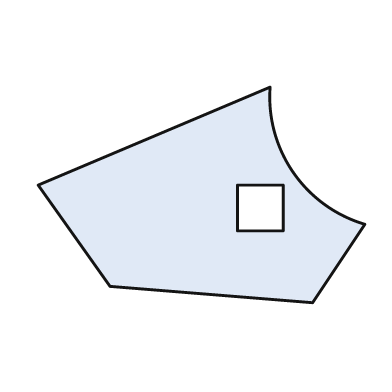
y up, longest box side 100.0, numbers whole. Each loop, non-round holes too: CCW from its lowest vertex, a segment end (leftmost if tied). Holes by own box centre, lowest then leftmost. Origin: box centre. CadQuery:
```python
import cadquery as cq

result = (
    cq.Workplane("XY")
    .moveTo(34.0, -33.0)
    .lineTo(50.0, -9.0)
    .threePointArc((28.0, 7.0), (21.0, 33.0))
    .lineTo(-50.0, 3.0)
    .lineTo(-28.0, -28.0)
    .close()
    .moveTo(11.0, -11.0)
    .lineTo(25.0, -11.0)
    .lineTo(25.0, 3.0)
    .lineTo(11.0, 3.0)
    .close()
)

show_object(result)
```